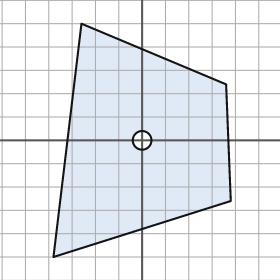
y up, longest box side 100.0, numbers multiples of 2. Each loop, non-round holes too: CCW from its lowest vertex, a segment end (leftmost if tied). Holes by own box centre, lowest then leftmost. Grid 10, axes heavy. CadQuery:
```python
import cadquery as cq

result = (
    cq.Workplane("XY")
    .moveTo(-38.0, -50.0)
    .lineTo(38.0, -26.0)
    .lineTo(36.0, 24.0)
    .lineTo(-26.0, 50.0)
    .close()
    .moveTo(0.0, 0.0)
    .circle(4.0)
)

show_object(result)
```